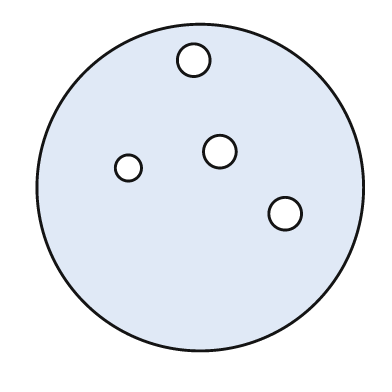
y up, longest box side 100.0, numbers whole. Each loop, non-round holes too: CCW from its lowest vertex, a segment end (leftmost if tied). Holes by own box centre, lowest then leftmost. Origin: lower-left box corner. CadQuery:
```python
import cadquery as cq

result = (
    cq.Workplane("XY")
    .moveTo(50.0, 50.0)
    .circle(50.0)
    .moveTo(76.0, 42.0)
    .circle(5.0)
    .moveTo(28.0, 56.0)
    .circle(4.0)
    .moveTo(56.0, 61.0)
    .circle(5.0)
    .moveTo(48.0, 89.0)
    .circle(5.0)
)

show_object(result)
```